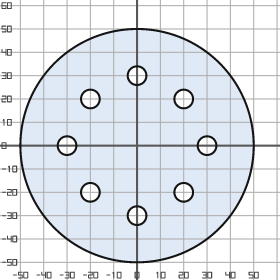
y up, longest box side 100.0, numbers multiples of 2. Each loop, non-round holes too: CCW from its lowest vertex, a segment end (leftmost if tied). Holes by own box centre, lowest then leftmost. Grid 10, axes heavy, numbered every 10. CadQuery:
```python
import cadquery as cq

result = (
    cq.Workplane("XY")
    .moveTo(0.0, 0.0)
    .circle(50.0)
    .moveTo(0.0, -30.0)
    .circle(4.0)
    .moveTo(-20.0, -20.0)
    .circle(4.0)
    .moveTo(20.0, -20.0)
    .circle(4.0)
    .moveTo(-30.0, 0.0)
    .circle(4.0)
    .moveTo(30.0, 0.0)
    .circle(4.0)
    .moveTo(-20.0, 20.0)
    .circle(4.0)
    .moveTo(20.0, 20.0)
    .circle(4.0)
    .moveTo(0.0, 30.0)
    .circle(4.0)
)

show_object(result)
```